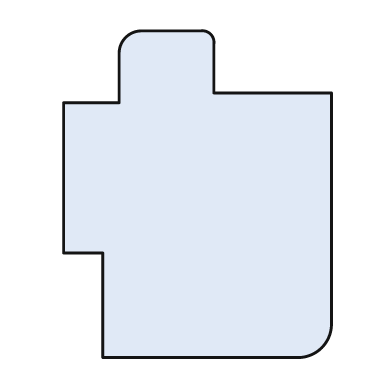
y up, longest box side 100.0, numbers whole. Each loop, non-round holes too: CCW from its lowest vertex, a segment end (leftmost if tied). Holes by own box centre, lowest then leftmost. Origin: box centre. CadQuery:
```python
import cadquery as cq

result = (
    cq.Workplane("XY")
    .moveTo(-29.0, -50.0)
    .lineTo(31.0, -50.0)
    .threePointArc((38.0, -47.0), (41.0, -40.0))
    .lineTo(41.0, 31.0)
    .lineTo(5.0, 31.0)
    .lineTo(5.0, 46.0)
    .threePointArc((4.0, 49.0), (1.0, 50.0))
    .lineTo(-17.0, 50.0)
    .threePointArc((-22.0, 48.0), (-24.0, 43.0))
    .lineTo(-24.0, 28.0)
    .lineTo(-41.0, 28.0)
    .lineTo(-41.0, -18.0)
    .lineTo(-29.0, -18.0)
    .close()
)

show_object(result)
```